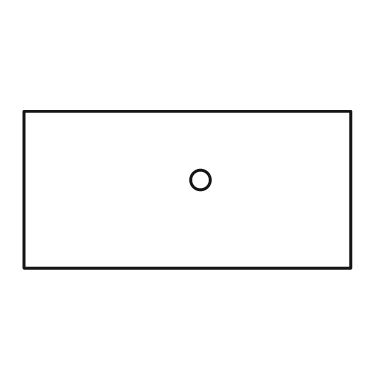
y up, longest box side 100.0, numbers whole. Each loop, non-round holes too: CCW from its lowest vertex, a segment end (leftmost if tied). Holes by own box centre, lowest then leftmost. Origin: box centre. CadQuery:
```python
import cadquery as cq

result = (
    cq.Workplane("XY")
    .moveTo(-50.0, -24.0)
    .lineTo(50.0, -24.0)
    .lineTo(50.0, 24.0)
    .lineTo(-50.0, 24.0)
    .close()
    .moveTo(4.0, 3.0)
    .circle(3.0)
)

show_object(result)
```